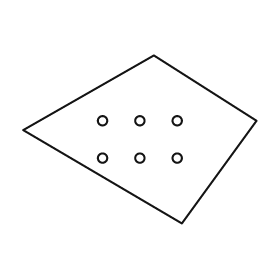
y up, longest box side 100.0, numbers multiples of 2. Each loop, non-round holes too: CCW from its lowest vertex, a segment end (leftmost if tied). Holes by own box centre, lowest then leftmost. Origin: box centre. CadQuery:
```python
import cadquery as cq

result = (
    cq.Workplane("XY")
    .moveTo(18.0, -36.0)
    .lineTo(50.0, 8.0)
    .lineTo(6.0, 36.0)
    .lineTo(-50.0, 4.0)
    .close()
    .moveTo(-16.0, -8.0)
    .circle(2.0)
    .moveTo(0.0, -8.0)
    .circle(2.0)
    .moveTo(16.0, -8.0)
    .circle(2.0)
    .moveTo(-16.0, 8.0)
    .circle(2.0)
    .moveTo(0.0, 8.0)
    .circle(2.0)
    .moveTo(16.0, 8.0)
    .circle(2.0)
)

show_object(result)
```